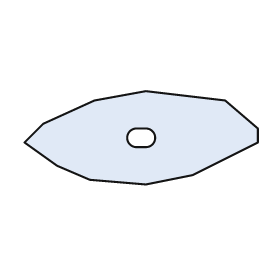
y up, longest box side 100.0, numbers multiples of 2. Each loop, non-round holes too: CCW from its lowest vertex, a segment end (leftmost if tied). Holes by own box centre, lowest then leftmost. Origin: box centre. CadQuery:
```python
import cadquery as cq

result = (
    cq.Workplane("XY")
    .moveTo(2.0, -20.0)
    .lineTo(22.0, -16.0)
    .lineTo(50.0, -2.0)
    .lineTo(50.0, 4.0)
    .lineTo(36.0, 16.0)
    .lineTo(2.0, 20.0)
    .lineTo(-20.0, 16.0)
    .lineTo(-42.0, 6.0)
    .lineTo(-50.0, -2.0)
    .lineTo(-36.0, -12.0)
    .lineTo(-22.0, -18.0)
    .close()
    .moveTo(-2.0, -4.0)
    .lineTo(2.0, -4.0)
    .threePointArc((6.0, 0.0), (2.0, 4.0))
    .lineTo(-2.0, 4.0)
    .threePointArc((-6.0, 0.0), (-2.0, -4.0))
    .close()
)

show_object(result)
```